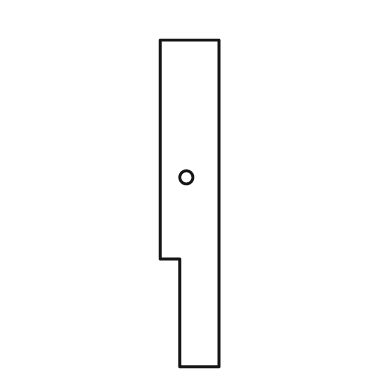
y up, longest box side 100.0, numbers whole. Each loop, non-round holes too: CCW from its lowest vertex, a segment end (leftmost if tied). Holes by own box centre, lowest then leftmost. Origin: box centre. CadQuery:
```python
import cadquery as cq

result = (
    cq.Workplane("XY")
    .moveTo(-3.0, -50.0)
    .lineTo(9.0, -50.0)
    .lineTo(9.0, 50.0)
    .lineTo(-9.0, 50.0)
    .lineTo(-9.0, -17.0)
    .lineTo(-3.0, -17.0)
    .close()
    .moveTo(-1.0, 8.0)
    .circle(2.0)
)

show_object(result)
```